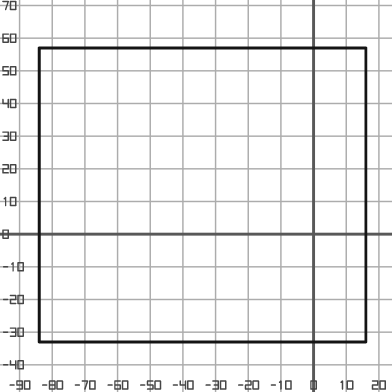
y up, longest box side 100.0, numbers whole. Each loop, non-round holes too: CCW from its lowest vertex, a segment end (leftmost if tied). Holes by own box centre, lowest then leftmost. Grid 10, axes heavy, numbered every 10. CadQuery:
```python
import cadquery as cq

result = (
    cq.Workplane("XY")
    .moveTo(-84.0, -33.0)
    .lineTo(16.0, -33.0)
    .lineTo(16.0, 57.0)
    .lineTo(-84.0, 57.0)
    .close()
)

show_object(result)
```